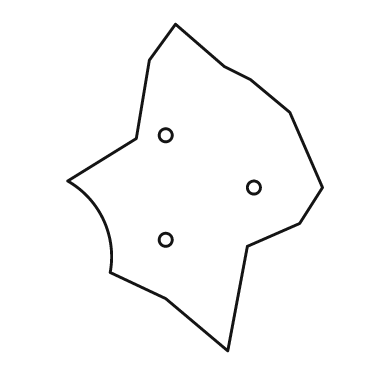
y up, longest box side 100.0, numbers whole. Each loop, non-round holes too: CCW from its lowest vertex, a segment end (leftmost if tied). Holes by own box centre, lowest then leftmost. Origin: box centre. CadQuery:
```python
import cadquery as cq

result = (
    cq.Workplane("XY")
    .moveTo(10.0, -50.0)
    .lineTo(16.0, -18.0)
    .lineTo(32.0, -11.0)
    .lineTo(39.0, 0.0)
    .lineTo(29.0, 23.0)
    .lineTo(17.0, 33.0)
    .lineTo(9.0, 37.0)
    .lineTo(-6.0, 50.0)
    .lineTo(-14.0, 39.0)
    .lineTo(-18.0, 15.0)
    .lineTo(-39.0, 2.0)
    .threePointArc((-28.0, -10.0), (-26.0, -26.0))
    .lineTo(-9.0, -34.0)
    .close()
    .moveTo(-9.0, -16.0)
    .circle(2.0)
    .moveTo(18.0, 0.0)
    .circle(2.0)
    .moveTo(-9.0, 16.0)
    .circle(2.0)
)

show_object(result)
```